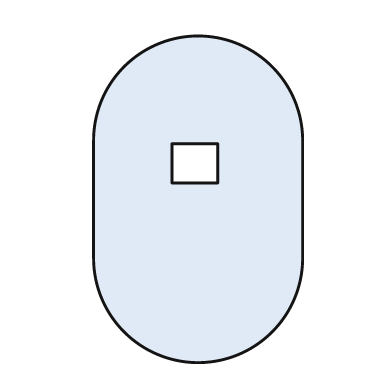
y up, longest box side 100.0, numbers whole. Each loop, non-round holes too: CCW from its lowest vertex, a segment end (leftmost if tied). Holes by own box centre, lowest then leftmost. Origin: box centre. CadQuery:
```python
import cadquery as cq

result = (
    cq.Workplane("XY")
    .moveTo(-32.0, -18.0)
    .threePointArc((0.0, -50.0), (32.0, -18.0))
    .lineTo(32.0, 18.0)
    .threePointArc((0.0, 50.0), (-32.0, 18.0))
    .close()
    .moveTo(-8.0, 5.0)
    .lineTo(6.0, 5.0)
    .lineTo(6.0, 17.0)
    .lineTo(-8.0, 17.0)
    .close()
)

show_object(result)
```